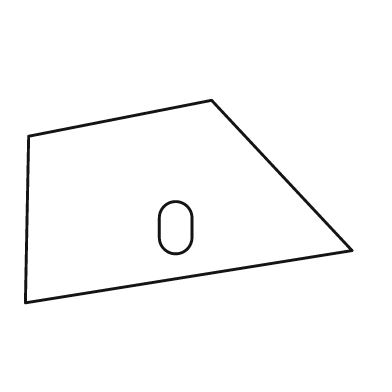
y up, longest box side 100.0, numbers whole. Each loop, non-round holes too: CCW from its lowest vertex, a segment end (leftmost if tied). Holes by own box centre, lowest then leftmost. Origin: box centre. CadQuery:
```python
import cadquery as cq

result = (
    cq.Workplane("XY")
    .moveTo(-50.0, -31.0)
    .lineTo(50.0, -15.0)
    .lineTo(7.0, 31.0)
    .lineTo(-49.0, 20.0)
    .close()
    .moveTo(-9.0, -11.0)
    .threePointArc((-4.0, -16.0), (1.0, -11.0))
    .lineTo(1.0, -5.0)
    .threePointArc((-4.0, 0.0), (-9.0, -5.0))
    .close()
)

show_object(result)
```